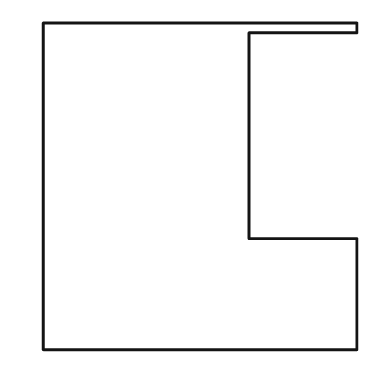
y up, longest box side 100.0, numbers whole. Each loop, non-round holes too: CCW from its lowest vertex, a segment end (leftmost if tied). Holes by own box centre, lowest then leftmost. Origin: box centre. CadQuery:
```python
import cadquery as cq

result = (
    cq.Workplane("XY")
    .moveTo(-48.0, -50.0)
    .lineTo(48.0, -50.0)
    .lineTo(48.0, -16.0)
    .lineTo(15.0, -16.0)
    .lineTo(15.0, 47.0)
    .lineTo(48.0, 47.0)
    .lineTo(48.0, 50.0)
    .lineTo(-48.0, 50.0)
    .close()
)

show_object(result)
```